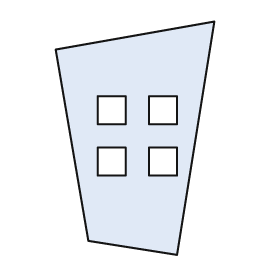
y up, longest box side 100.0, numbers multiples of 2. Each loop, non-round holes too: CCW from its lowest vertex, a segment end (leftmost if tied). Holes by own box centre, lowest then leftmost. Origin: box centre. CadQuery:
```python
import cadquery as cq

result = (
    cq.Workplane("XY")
    .moveTo(18.0, -50.0)
    .lineTo(34.0, 50.0)
    .lineTo(-34.0, 38.0)
    .lineTo(-20.0, -44.0)
    .close()
    .moveTo(-16.0, -16.0)
    .lineTo(-4.0, -16.0)
    .lineTo(-4.0, -4.0)
    .lineTo(-16.0, -4.0)
    .close()
    .moveTo(6.0, -16.0)
    .lineTo(18.0, -16.0)
    .lineTo(18.0, -4.0)
    .lineTo(6.0, -4.0)
    .close()
    .moveTo(-16.0, 6.0)
    .lineTo(-4.0, 6.0)
    .lineTo(-4.0, 18.0)
    .lineTo(-16.0, 18.0)
    .close()
    .moveTo(6.0, 6.0)
    .lineTo(18.0, 6.0)
    .lineTo(18.0, 18.0)
    .lineTo(6.0, 18.0)
    .close()
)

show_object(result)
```